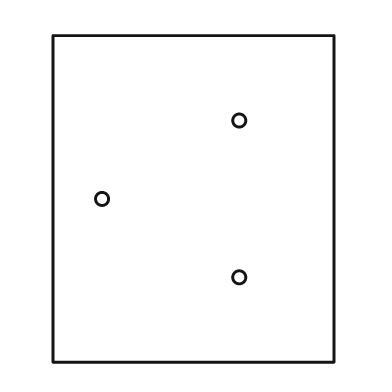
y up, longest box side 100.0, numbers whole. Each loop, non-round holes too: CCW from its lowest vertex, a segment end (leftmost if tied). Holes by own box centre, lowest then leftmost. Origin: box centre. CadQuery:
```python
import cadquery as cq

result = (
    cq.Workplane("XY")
    .moveTo(-43.0, -50.0)
    .lineTo(43.0, -50.0)
    .lineTo(43.0, 50.0)
    .lineTo(-43.0, 50.0)
    .close()
    .moveTo(14.0, -24.0)
    .circle(2.0)
    .moveTo(-28.0, 0.0)
    .circle(2.0)
    .moveTo(14.0, 24.0)
    .circle(2.0)
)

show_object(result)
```